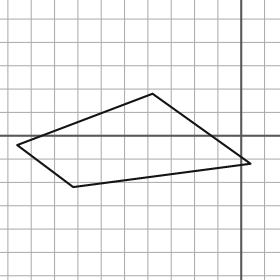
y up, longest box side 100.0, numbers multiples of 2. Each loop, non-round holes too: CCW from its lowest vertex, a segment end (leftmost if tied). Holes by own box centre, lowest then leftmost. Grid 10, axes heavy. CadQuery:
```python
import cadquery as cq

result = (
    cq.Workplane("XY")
    .moveTo(-72.0, -22.0)
    .lineTo(4.0, -12.0)
    .lineTo(-38.0, 18.0)
    .lineTo(-96.0, -4.0)
    .close()
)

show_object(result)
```